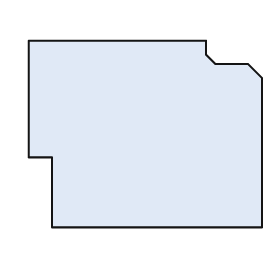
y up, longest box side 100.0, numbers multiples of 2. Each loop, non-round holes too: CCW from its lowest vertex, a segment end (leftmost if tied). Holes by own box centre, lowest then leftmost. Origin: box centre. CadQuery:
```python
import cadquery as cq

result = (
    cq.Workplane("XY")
    .moveTo(-40.0, -40.0)
    .lineTo(50.0, -40.0)
    .lineTo(50.0, 24.0)
    .lineTo(44.0, 30.0)
    .lineTo(30.0, 30.0)
    .lineTo(26.0, 34.0)
    .lineTo(26.0, 40.0)
    .lineTo(-50.0, 40.0)
    .lineTo(-50.0, -10.0)
    .lineTo(-40.0, -10.0)
    .close()
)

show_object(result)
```